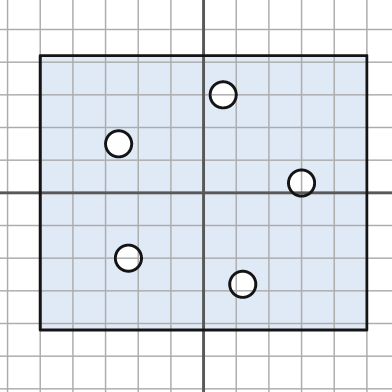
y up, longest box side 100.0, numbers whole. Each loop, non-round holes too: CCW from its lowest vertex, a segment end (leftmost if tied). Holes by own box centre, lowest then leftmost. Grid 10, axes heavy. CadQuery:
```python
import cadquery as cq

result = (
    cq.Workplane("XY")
    .moveTo(-50.0, -42.0)
    .lineTo(50.0, -42.0)
    .lineTo(50.0, 42.0)
    .lineTo(-50.0, 42.0)
    .close()
    .moveTo(12.0, -28.0)
    .circle(4.0)
    .moveTo(-23.0, -20.0)
    .circle(4.0)
    .moveTo(30.0, 3.0)
    .circle(4.0)
    .moveTo(-26.0, 15.0)
    .circle(4.0)
    .moveTo(6.0, 30.0)
    .circle(4.0)
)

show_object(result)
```